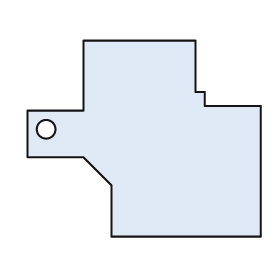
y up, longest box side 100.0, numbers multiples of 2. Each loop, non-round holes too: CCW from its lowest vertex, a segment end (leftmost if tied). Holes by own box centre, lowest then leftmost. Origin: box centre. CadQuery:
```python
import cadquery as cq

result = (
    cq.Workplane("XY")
    .moveTo(-14.0, -42.0)
    .lineTo(50.0, -42.0)
    .lineTo(50.0, 14.0)
    .lineTo(26.0, 14.0)
    .lineTo(26.0, 20.0)
    .lineTo(22.0, 20.0)
    .lineTo(22.0, 42.0)
    .lineTo(-26.0, 42.0)
    .lineTo(-26.0, 12.0)
    .lineTo(-50.0, 12.0)
    .lineTo(-50.0, -8.0)
    .lineTo(-26.0, -8.0)
    .lineTo(-14.0, -20.0)
    .close()
    .moveTo(-42.0, 4.0)
    .circle(4.0)
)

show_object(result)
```